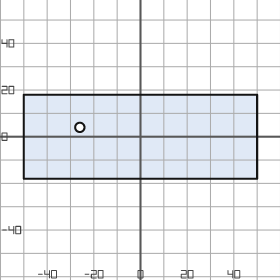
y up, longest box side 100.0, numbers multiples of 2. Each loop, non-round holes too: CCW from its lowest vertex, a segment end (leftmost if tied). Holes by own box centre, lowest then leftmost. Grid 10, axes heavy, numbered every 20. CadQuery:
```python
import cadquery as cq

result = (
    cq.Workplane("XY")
    .moveTo(-50.0, -18.0)
    .lineTo(50.0, -18.0)
    .lineTo(50.0, 18.0)
    .lineTo(-50.0, 18.0)
    .close()
    .moveTo(-26.0, 4.0)
    .circle(2.0)
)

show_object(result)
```